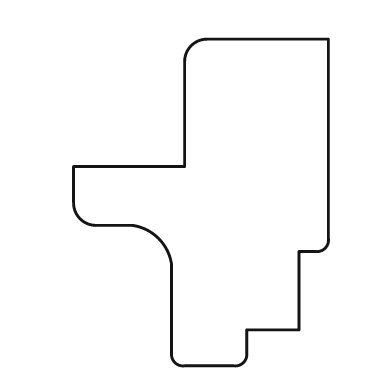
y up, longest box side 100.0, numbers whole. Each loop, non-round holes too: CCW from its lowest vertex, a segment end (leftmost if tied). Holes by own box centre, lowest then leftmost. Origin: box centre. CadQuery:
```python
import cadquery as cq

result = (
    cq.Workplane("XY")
    .moveTo(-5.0, -50.0)
    .lineTo(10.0, -50.0)
    .threePointArc((13.0, -49.0), (14.0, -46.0))
    .lineTo(14.0, -39.0)
    .lineTo(30.0, -39.0)
    .lineTo(30.0, -15.0)
    .lineTo(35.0, -15.0)
    .threePointArc((38.0, -14.0), (39.0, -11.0))
    .lineTo(39.0, 50.0)
    .lineTo(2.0, 50.0)
    .threePointArc((-3.0, 48.0), (-5.0, 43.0))
    .lineTo(-5.0, 11.0)
    .lineTo(-39.0, 11.0)
    .lineTo(-39.0, 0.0)
    .threePointArc((-37.0, -5.0), (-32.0, -7.0))
    .lineTo(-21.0, -7.0)
    .threePointArc((-13.0, -11.0), (-9.0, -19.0))
    .lineTo(-9.0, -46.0)
    .threePointArc((-8.0, -49.0), (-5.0, -50.0))
    .close()
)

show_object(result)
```